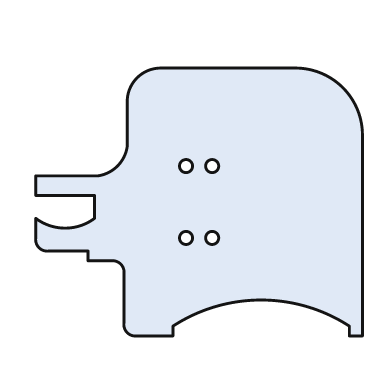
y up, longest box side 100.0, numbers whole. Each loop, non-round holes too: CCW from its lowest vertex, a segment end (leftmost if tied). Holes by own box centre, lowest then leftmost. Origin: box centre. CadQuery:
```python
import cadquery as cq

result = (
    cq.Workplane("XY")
    .moveTo(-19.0, -41.0)
    .lineTo(-8.0, -41.0)
    .lineTo(-8.0, -38.0)
    .threePointArc((19.0, -30.0), (46.0, -38.0))
    .lineTo(46.0, -41.0)
    .lineTo(50.0, -41.0)
    .lineTo(50.0, 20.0)
    .threePointArc((44.0, 35.0), (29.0, 41.0))
    .lineTo(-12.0, 41.0)
    .threePointArc((-19.0, 38.0), (-22.0, 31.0))
    .lineTo(-22.0, 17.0)
    .threePointArc((-25.0, 11.0), (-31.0, 8.0))
    .lineTo(-50.0, 8.0)
    .lineTo(-50.0, 2.0)
    .lineTo(-32.0, 2.0)
    .lineTo(-32.0, -5.0)
    .threePointArc((-41.0, -8.0), (-50.0, -5.0))
    .lineTo(-50.0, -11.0)
    .threePointArc((-49.0, -14.0), (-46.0, -15.0))
    .lineTo(-34.0, -15.0)
    .lineTo(-34.0, -18.0)
    .lineTo(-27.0, -18.0)
    .threePointArc((-24.0, -19.0), (-23.0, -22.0))
    .lineTo(-23.0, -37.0)
    .threePointArc((-22.0, -40.0), (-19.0, -41.0))
    .close()
    .moveTo(-4.0, -11.0)
    .circle(2.0)
    .moveTo(4.0, -11.0)
    .circle(2.0)
    .moveTo(-4.0, 11.0)
    .circle(2.0)
    .moveTo(4.0, 11.0)
    .circle(2.0)
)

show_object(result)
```